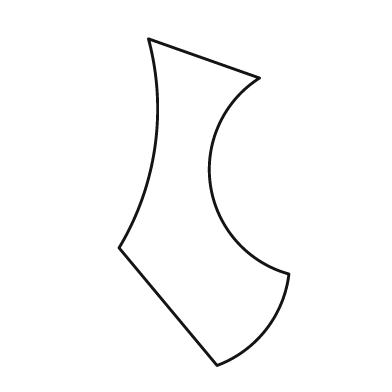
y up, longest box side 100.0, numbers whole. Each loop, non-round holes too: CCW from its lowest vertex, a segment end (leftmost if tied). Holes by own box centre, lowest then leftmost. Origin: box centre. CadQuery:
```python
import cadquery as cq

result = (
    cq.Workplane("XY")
    .moveTo(4.0, -50.0)
    .threePointArc((19.0, -39.0), (26.0, -22.0))
    .threePointArc((2.0, 5.0), (17.0, 38.0))
    .lineTo(-17.0, 50.0)
    .threePointArc((-15.0, 17.0), (-26.0, -14.0))
    .close()
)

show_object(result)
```